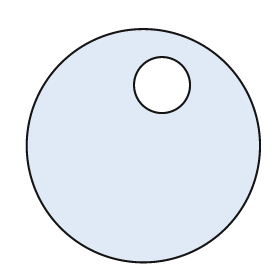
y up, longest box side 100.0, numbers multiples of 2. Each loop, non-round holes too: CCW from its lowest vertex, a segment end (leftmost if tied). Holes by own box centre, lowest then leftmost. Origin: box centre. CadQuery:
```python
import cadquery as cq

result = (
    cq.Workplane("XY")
    .moveTo(0.0, 0.0)
    .circle(50.0)
    .moveTo(8.0, 26.0)
    .circle(12.0)
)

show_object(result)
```